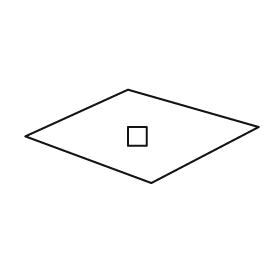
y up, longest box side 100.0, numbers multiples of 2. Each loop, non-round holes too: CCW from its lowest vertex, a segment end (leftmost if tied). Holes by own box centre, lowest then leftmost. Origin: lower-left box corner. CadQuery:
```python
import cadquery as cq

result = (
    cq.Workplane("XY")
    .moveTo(54.0, 0.0)
    .lineTo(100.0, 24.0)
    .lineTo(44.0, 40.0)
    .lineTo(0.0, 20.0)
    .close()
    .moveTo(44.0, 16.0)
    .lineTo(52.0, 16.0)
    .lineTo(52.0, 24.0)
    .lineTo(44.0, 24.0)
    .close()
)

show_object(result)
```